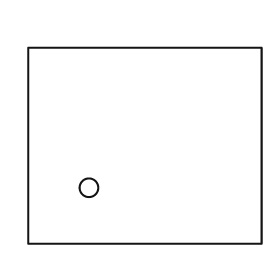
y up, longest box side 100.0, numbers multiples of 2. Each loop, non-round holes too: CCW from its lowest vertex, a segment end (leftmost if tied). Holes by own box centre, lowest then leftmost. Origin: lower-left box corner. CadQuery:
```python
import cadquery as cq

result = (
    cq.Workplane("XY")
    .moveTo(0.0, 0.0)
    .lineTo(100.0, 0.0)
    .lineTo(100.0, 84.0)
    .lineTo(0.0, 84.0)
    .close()
    .moveTo(26.0, 24.0)
    .circle(4.0)
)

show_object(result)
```